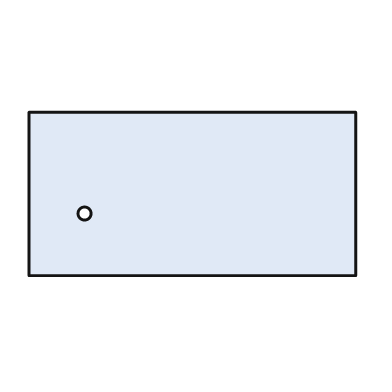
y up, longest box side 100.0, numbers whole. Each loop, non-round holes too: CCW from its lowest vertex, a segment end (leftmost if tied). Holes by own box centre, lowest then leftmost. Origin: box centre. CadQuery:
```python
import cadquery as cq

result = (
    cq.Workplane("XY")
    .moveTo(-50.0, -25.0)
    .lineTo(50.0, -25.0)
    .lineTo(50.0, 25.0)
    .lineTo(-50.0, 25.0)
    .close()
    .moveTo(-33.0, -6.0)
    .circle(2.0)
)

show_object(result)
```